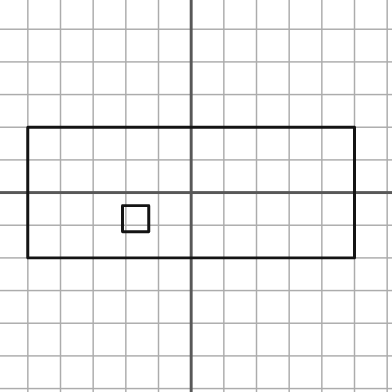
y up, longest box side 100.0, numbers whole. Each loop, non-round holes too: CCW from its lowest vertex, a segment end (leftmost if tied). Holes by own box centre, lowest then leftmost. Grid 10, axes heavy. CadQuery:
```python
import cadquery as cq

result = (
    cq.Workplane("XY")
    .moveTo(-50.0, -20.0)
    .lineTo(50.0, -20.0)
    .lineTo(50.0, 20.0)
    .lineTo(-50.0, 20.0)
    .close()
    .moveTo(-21.0, -12.0)
    .lineTo(-13.0, -12.0)
    .lineTo(-13.0, -4.0)
    .lineTo(-21.0, -4.0)
    .close()
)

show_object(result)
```